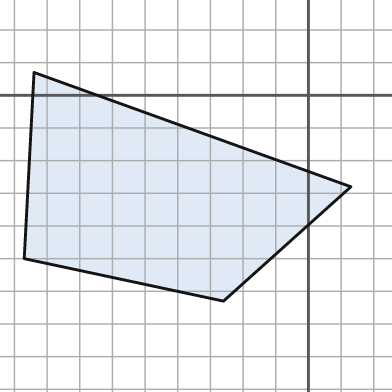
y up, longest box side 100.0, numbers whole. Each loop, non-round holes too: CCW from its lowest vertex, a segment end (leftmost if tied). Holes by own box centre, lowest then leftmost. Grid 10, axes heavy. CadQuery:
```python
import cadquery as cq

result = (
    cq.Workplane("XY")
    .moveTo(-26.0, -63.0)
    .lineTo(13.0, -28.0)
    .lineTo(-84.0, 7.0)
    .lineTo(-87.0, -50.0)
    .close()
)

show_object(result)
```